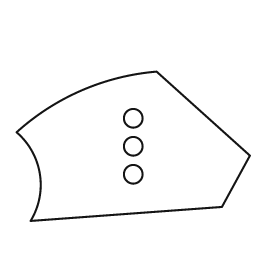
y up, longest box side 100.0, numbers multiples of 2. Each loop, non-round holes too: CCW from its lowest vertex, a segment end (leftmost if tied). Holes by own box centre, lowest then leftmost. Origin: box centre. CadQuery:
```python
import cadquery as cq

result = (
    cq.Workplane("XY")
    .moveTo(-44.0, -32.0)
    .lineTo(38.0, -26.0)
    .lineTo(50.0, -4.0)
    .lineTo(10.0, 32.0)
    .threePointArc((-22.0, 24.0), (-50.0, 6.0))
    .threePointArc((-40.0, -12.0), (-44.0, -32.0))
    .close()
    .moveTo(0.0, -12.0)
    .circle(4.0)
    .moveTo(0.0, 0.0)
    .circle(4.0)
    .moveTo(0.0, 12.0)
    .circle(4.0)
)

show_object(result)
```